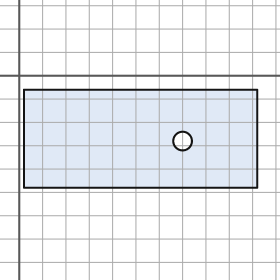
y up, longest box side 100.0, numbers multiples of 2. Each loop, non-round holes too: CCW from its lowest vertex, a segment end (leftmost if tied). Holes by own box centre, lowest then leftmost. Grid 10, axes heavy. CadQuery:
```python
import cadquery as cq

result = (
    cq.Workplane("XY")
    .moveTo(2.0, -48.0)
    .lineTo(102.0, -48.0)
    .lineTo(102.0, -6.0)
    .lineTo(2.0, -6.0)
    .close()
    .moveTo(70.0, -28.0)
    .circle(4.0)
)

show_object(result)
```